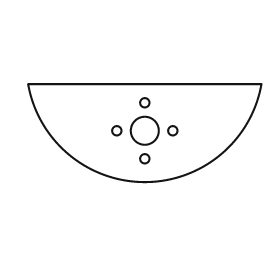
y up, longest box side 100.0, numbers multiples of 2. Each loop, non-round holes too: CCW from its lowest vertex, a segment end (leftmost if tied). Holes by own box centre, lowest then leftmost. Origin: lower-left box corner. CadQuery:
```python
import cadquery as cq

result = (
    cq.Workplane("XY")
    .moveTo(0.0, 42.0)
    .threePointArc((50.0, 0.0), (100.0, 42.0))
    .close()
    .moveTo(50.0, 10.0)
    .circle(2.0)
    .moveTo(38.0, 22.0)
    .circle(2.0)
    .moveTo(50.0, 22.0)
    .circle(6.0)
    .moveTo(62.0, 22.0)
    .circle(2.0)
    .moveTo(50.0, 34.0)
    .circle(2.0)
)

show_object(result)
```